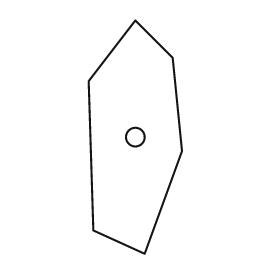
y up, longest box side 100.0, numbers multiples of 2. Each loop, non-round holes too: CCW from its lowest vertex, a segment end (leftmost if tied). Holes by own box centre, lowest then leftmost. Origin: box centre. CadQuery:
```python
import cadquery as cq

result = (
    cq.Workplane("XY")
    .moveTo(4.0, -50.0)
    .lineTo(20.0, -6.0)
    .lineTo(16.0, 34.0)
    .lineTo(0.0, 50.0)
    .lineTo(-20.0, 24.0)
    .lineTo(-18.0, -40.0)
    .close()
    .moveTo(0.0, 0.0)
    .circle(4.0)
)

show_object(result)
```